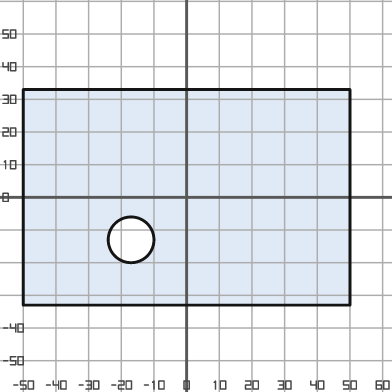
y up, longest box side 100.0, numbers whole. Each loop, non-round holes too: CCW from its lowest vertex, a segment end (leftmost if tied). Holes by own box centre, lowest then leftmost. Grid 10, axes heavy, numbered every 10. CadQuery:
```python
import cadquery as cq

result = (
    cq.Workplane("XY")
    .moveTo(-50.0, -33.0)
    .lineTo(50.0, -33.0)
    .lineTo(50.0, 33.0)
    .lineTo(-50.0, 33.0)
    .close()
    .moveTo(-17.0, -13.0)
    .circle(7.0)
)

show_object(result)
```